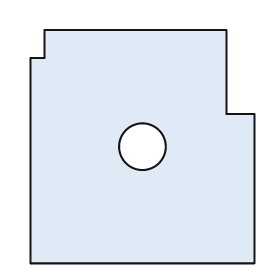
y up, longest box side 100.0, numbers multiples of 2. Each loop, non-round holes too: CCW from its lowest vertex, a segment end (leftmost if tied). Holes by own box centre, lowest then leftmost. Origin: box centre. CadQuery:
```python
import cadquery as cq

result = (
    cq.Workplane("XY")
    .moveTo(-48.0, -50.0)
    .lineTo(48.0, -50.0)
    .lineTo(48.0, 14.0)
    .lineTo(36.0, 14.0)
    .lineTo(36.0, 50.0)
    .lineTo(-42.0, 50.0)
    .lineTo(-42.0, 38.0)
    .lineTo(-48.0, 38.0)
    .close()
    .moveTo(0.0, 0.0)
    .circle(10.0)
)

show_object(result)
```